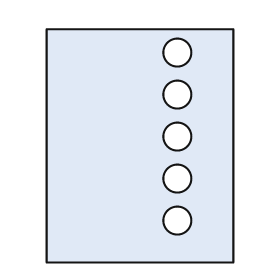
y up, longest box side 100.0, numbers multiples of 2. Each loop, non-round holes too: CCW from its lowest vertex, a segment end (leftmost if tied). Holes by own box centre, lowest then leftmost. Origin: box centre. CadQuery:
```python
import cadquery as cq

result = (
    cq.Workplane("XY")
    .moveTo(-40.0, -50.0)
    .lineTo(40.0, -50.0)
    .lineTo(40.0, 50.0)
    .lineTo(-40.0, 50.0)
    .close()
    .moveTo(16.0, -32.0)
    .circle(6.0)
    .moveTo(16.0, -14.0)
    .circle(6.0)
    .moveTo(16.0, 4.0)
    .circle(6.0)
    .moveTo(16.0, 22.0)
    .circle(6.0)
    .moveTo(16.0, 40.0)
    .circle(6.0)
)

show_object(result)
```